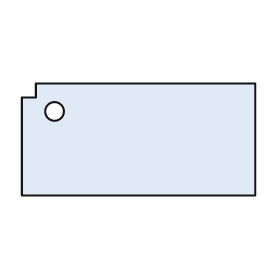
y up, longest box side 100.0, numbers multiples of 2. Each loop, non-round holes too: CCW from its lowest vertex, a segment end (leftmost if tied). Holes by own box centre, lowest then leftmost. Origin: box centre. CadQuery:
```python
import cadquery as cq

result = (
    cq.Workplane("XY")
    .moveTo(-50.0, -24.0)
    .lineTo(50.0, -24.0)
    .lineTo(50.0, 24.0)
    .lineTo(-44.0, 24.0)
    .lineTo(-44.0, 18.0)
    .lineTo(-50.0, 18.0)
    .close()
    .moveTo(-36.0, 12.0)
    .circle(4.0)
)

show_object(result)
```